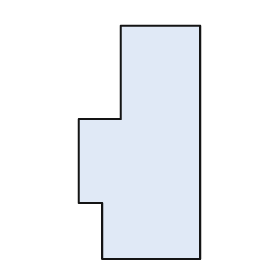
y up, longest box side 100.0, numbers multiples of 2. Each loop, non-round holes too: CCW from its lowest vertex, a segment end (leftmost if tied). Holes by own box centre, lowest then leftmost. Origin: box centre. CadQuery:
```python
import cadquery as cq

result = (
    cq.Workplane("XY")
    .moveTo(-16.0, -50.0)
    .lineTo(26.0, -50.0)
    .lineTo(26.0, 50.0)
    .lineTo(-8.0, 50.0)
    .lineTo(-8.0, 10.0)
    .lineTo(-26.0, 10.0)
    .lineTo(-26.0, -26.0)
    .lineTo(-16.0, -26.0)
    .close()
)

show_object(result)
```